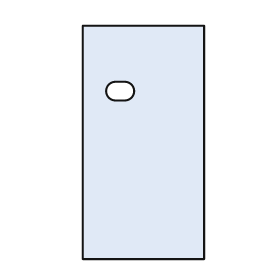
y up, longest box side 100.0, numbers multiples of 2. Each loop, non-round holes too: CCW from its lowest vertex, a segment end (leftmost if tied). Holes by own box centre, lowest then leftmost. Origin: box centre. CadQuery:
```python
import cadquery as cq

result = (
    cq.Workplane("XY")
    .moveTo(-26.0, -50.0)
    .lineTo(26.0, -50.0)
    .lineTo(26.0, 50.0)
    .lineTo(-26.0, 50.0)
    .close()
    .moveTo(-12.0, 18.0)
    .lineTo(-8.0, 18.0)
    .threePointArc((-4.0, 22.0), (-8.0, 26.0))
    .lineTo(-12.0, 26.0)
    .threePointArc((-16.0, 22.0), (-12.0, 18.0))
    .close()
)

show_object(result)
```